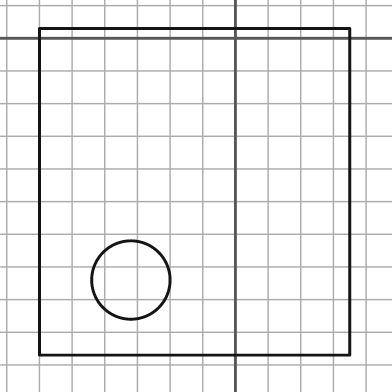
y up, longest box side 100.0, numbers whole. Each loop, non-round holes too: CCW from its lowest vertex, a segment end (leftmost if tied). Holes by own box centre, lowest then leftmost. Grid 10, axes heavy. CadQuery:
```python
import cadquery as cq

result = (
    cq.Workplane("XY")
    .moveTo(-60.0, -97.0)
    .lineTo(35.0, -97.0)
    .lineTo(35.0, 3.0)
    .lineTo(-60.0, 3.0)
    .close()
    .moveTo(-32.0, -74.0)
    .circle(12.0)
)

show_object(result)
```